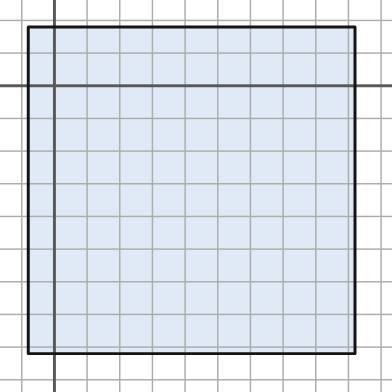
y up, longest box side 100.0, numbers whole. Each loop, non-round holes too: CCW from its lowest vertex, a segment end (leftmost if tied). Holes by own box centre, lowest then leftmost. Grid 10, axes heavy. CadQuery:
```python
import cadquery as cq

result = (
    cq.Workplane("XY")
    .moveTo(-8.0, -82.0)
    .lineTo(92.0, -82.0)
    .lineTo(92.0, 18.0)
    .lineTo(-8.0, 18.0)
    .close()
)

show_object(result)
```